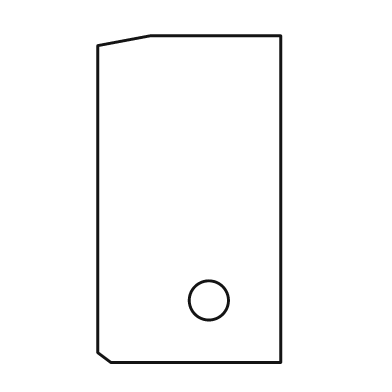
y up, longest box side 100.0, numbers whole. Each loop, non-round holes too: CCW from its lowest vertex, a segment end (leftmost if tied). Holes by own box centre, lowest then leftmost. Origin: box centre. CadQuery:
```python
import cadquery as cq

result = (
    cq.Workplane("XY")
    .moveTo(-24.0, -50.0)
    .lineTo(28.0, -50.0)
    .lineTo(28.0, 50.0)
    .lineTo(-12.0, 50.0)
    .lineTo(-28.0, 47.0)
    .lineTo(-28.0, -47.0)
    .close()
    .moveTo(6.0, -31.0)
    .circle(6.0)
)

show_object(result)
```